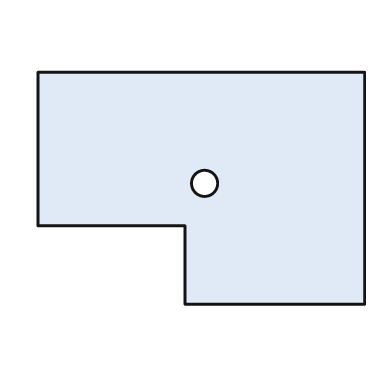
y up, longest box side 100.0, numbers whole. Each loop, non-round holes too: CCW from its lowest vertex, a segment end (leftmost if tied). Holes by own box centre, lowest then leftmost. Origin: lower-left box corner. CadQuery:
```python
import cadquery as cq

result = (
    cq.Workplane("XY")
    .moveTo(45.0, 0.0)
    .lineTo(100.0, 0.0)
    .lineTo(100.0, 71.0)
    .lineTo(0.0, 71.0)
    .lineTo(0.0, 24.0)
    .lineTo(45.0, 24.0)
    .close()
    .moveTo(51.0, 37.0)
    .circle(4.0)
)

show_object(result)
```